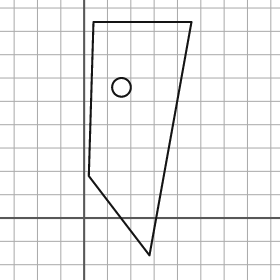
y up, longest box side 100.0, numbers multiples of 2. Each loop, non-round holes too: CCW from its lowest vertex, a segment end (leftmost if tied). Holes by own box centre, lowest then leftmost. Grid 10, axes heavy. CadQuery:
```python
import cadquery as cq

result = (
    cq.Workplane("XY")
    .moveTo(28.0, -16.0)
    .lineTo(46.0, 84.0)
    .lineTo(4.0, 84.0)
    .lineTo(2.0, 18.0)
    .close()
    .moveTo(16.0, 56.0)
    .circle(4.0)
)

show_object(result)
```